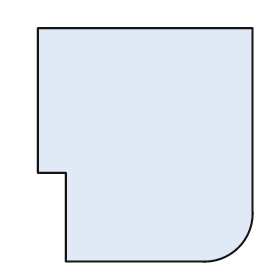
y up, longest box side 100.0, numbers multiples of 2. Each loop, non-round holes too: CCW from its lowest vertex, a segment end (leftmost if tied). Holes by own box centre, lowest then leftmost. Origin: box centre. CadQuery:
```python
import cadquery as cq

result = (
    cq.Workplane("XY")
    .moveTo(-34.0, -50.0)
    .lineTo(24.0, -50.0)
    .threePointArc((40.0, -44.0), (46.0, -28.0))
    .lineTo(46.0, 50.0)
    .lineTo(-46.0, 50.0)
    .lineTo(-46.0, -12.0)
    .lineTo(-34.0, -12.0)
    .close()
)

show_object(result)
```